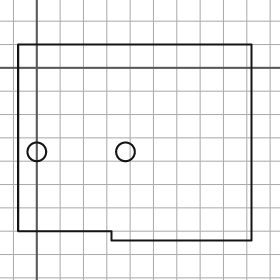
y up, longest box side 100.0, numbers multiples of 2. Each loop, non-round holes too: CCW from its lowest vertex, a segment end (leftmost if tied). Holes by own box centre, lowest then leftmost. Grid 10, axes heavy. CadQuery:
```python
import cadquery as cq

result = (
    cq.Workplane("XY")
    .moveTo(32.0, -74.0)
    .lineTo(92.0, -74.0)
    .lineTo(92.0, 10.0)
    .lineTo(-8.0, 10.0)
    .lineTo(-8.0, -70.0)
    .lineTo(32.0, -70.0)
    .close()
    .moveTo(0.0, -36.0)
    .circle(4.0)
    .moveTo(38.0, -36.0)
    .circle(4.0)
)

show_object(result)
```